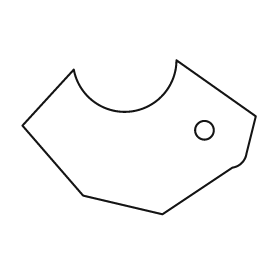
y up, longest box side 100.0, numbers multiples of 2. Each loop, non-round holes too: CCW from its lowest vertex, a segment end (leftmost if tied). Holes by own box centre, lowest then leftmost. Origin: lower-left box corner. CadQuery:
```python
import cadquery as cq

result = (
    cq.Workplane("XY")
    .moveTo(60.0, 0.0)
    .lineTo(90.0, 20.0)
    .threePointArc((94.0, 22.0), (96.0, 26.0))
    .lineTo(100.0, 42.0)
    .lineTo(66.0, 66.0)
    .threePointArc((46.0, 44.0), (22.0, 62.0))
    .lineTo(0.0, 38.0)
    .lineTo(26.0, 8.0)
    .close()
    .moveTo(78.0, 36.0)
    .circle(4.0)
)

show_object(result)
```